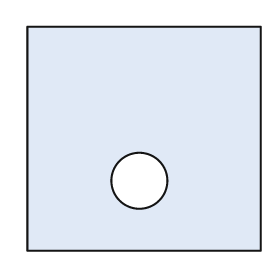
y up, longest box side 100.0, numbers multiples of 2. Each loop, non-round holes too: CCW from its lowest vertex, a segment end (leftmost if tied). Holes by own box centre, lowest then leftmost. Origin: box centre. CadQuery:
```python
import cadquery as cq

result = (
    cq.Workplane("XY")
    .moveTo(-50.0, -48.0)
    .lineTo(50.0, -48.0)
    .lineTo(50.0, 48.0)
    .lineTo(-50.0, 48.0)
    .close()
    .moveTo(-2.0, -18.0)
    .circle(12.0)
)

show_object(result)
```